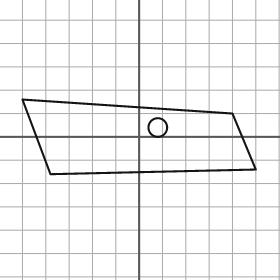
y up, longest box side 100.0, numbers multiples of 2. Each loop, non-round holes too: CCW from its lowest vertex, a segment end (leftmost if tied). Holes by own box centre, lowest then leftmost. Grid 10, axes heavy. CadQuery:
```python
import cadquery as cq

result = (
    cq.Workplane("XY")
    .moveTo(-38.0, -16.0)
    .lineTo(50.0, -14.0)
    .lineTo(40.0, 10.0)
    .lineTo(-50.0, 16.0)
    .close()
    .moveTo(8.0, 4.0)
    .circle(4.0)
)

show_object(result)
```